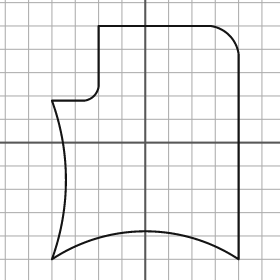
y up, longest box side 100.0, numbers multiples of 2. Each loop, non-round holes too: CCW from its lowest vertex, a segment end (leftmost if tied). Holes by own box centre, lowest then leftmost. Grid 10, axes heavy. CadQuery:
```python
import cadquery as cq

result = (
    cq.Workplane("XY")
    .moveTo(-40.0, -50.0)
    .threePointArc((0.0, -38.0), (40.0, -50.0))
    .lineTo(40.0, 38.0)
    .threePointArc((36.0, 46.0), (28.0, 50.0))
    .lineTo(-20.0, 50.0)
    .lineTo(-20.0, 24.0)
    .threePointArc((-22.0, 20.0), (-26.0, 18.0))
    .lineTo(-40.0, 18.0)
    .threePointArc((-34.0, -16.0), (-40.0, -50.0))
    .close()
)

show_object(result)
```